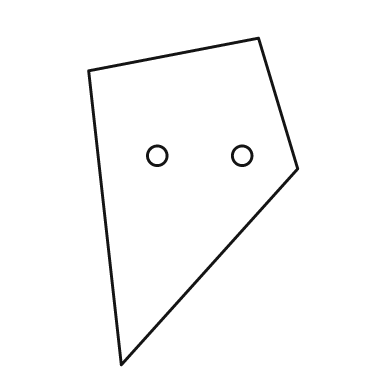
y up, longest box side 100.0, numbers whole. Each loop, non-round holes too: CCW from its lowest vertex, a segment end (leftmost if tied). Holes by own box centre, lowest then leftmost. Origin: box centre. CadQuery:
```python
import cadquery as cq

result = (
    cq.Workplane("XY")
    .moveTo(-22.0, -50.0)
    .lineTo(32.0, 10.0)
    .lineTo(20.0, 50.0)
    .lineTo(-32.0, 40.0)
    .close()
    .moveTo(-11.0, 14.0)
    .circle(3.0)
    .moveTo(15.0, 14.0)
    .circle(3.0)
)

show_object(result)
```